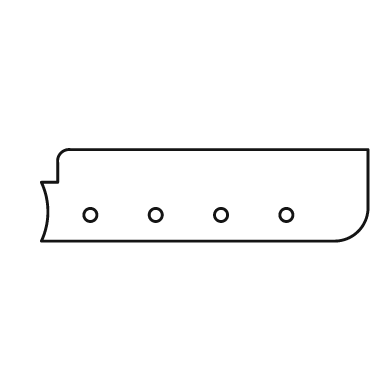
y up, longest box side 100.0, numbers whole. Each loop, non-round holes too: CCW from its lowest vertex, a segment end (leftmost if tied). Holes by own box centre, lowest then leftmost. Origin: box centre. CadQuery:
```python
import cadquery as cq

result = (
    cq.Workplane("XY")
    .moveTo(-50.0, -14.0)
    .lineTo(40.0, -14.0)
    .threePointArc((47.0, -11.0), (50.0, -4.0))
    .lineTo(50.0, 14.0)
    .lineTo(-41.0, 14.0)
    .threePointArc((-44.0, 13.0), (-45.0, 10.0))
    .lineTo(-45.0, 4.0)
    .lineTo(-50.0, 4.0)
    .threePointArc((-48.0, -5.0), (-50.0, -14.0))
    .close()
    .moveTo(-35.0, -6.0)
    .circle(2.0)
    .moveTo(-15.0, -6.0)
    .circle(2.0)
    .moveTo(5.0, -6.0)
    .circle(2.0)
    .moveTo(25.0, -6.0)
    .circle(2.0)
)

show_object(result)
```